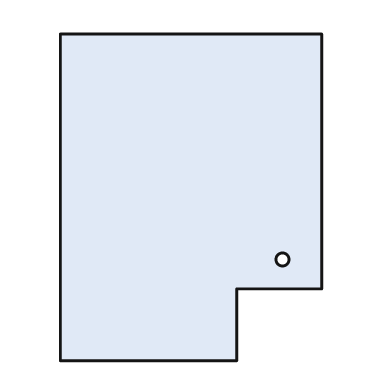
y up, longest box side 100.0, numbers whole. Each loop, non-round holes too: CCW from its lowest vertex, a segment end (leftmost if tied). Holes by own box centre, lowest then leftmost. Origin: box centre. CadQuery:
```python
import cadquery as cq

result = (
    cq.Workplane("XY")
    .moveTo(-40.0, -50.0)
    .lineTo(14.0, -50.0)
    .lineTo(14.0, -28.0)
    .lineTo(40.0, -28.0)
    .lineTo(40.0, 50.0)
    .lineTo(-40.0, 50.0)
    .close()
    .moveTo(28.0, -19.0)
    .circle(2.0)
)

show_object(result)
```